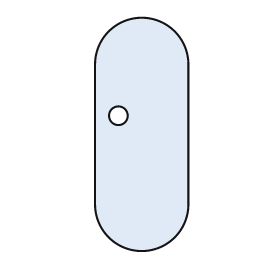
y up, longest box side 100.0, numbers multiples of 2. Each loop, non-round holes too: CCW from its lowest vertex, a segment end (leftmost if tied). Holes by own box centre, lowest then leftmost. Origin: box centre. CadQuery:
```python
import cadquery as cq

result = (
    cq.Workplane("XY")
    .moveTo(-20.0, -30.0)
    .threePointArc((0.0, -50.0), (20.0, -30.0))
    .lineTo(20.0, 30.0)
    .threePointArc((0.0, 50.0), (-20.0, 30.0))
    .close()
    .moveTo(-10.0, 8.0)
    .circle(4.0)
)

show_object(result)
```